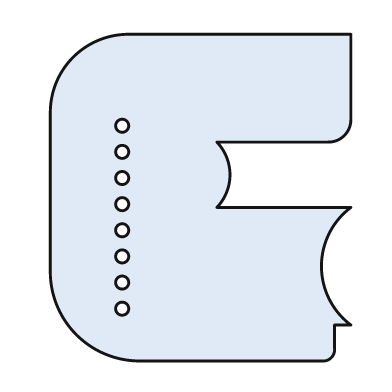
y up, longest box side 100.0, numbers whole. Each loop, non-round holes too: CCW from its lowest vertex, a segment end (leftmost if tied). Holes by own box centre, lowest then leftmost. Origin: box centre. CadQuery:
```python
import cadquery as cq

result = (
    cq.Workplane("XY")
    .moveTo(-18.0, -50.0)
    .lineTo(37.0, -50.0)
    .threePointArc((40.0, -49.0), (41.0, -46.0))
    .lineTo(41.0, -39.0)
    .lineTo(46.0, -39.0)
    .threePointArc((37.0, -21.0), (46.0, -3.0))
    .lineTo(5.0, -3.0)
    .threePointArc((9.0, 7.0), (5.0, 17.0))
    .lineTo(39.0, 17.0)
    .threePointArc((44.0, 19.0), (46.0, 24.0))
    .lineTo(46.0, 50.0)
    .lineTo(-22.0, 50.0)
    .threePointArc((-39.0, 43.0), (-46.0, 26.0))
    .lineTo(-46.0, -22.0)
    .threePointArc((-38.0, -42.0), (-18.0, -50.0))
    .close()
    .moveTo(-24.0, -34.0)
    .circle(2.0)
    .moveTo(-24.0, -26.0)
    .circle(2.0)
    .moveTo(-24.0, -18.0)
    .circle(2.0)
    .moveTo(-24.0, -10.0)
    .circle(2.0)
    .moveTo(-24.0, -2.0)
    .circle(2.0)
    .moveTo(-24.0, 6.0)
    .circle(2.0)
    .moveTo(-24.0, 14.0)
    .circle(2.0)
    .moveTo(-24.0, 22.0)
    .circle(2.0)
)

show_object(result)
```